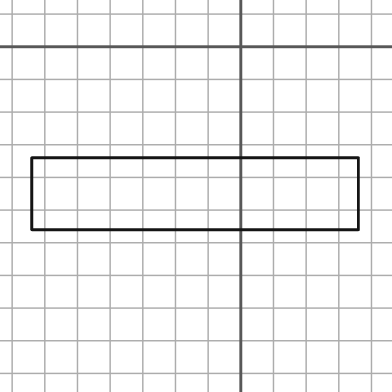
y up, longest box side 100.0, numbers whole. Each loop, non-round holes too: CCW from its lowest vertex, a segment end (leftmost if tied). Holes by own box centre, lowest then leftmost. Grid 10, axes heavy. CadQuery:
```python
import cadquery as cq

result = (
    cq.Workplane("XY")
    .moveTo(-64.0, -56.0)
    .lineTo(36.0, -56.0)
    .lineTo(36.0, -34.0)
    .lineTo(-64.0, -34.0)
    .close()
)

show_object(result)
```